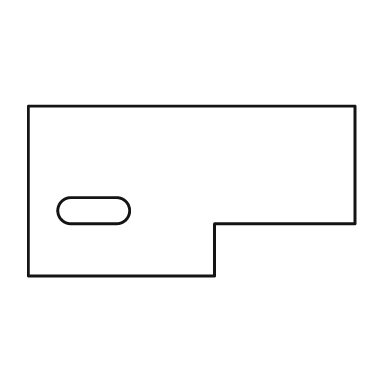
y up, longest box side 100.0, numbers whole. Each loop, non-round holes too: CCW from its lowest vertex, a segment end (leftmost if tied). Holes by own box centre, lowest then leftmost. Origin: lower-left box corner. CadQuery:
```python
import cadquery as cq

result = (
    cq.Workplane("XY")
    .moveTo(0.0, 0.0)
    .lineTo(57.0, 0.0)
    .lineTo(57.0, 16.0)
    .lineTo(100.0, 16.0)
    .lineTo(100.0, 52.0)
    .lineTo(0.0, 52.0)
    .close()
    .moveTo(13.0, 16.0)
    .lineTo(27.0, 16.0)
    .threePointArc((31.0, 20.0), (27.0, 24.0))
    .lineTo(13.0, 24.0)
    .threePointArc((9.0, 20.0), (13.0, 16.0))
    .close()
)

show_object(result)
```